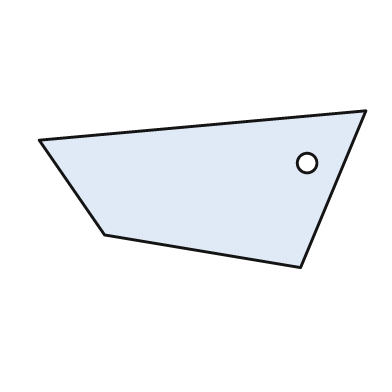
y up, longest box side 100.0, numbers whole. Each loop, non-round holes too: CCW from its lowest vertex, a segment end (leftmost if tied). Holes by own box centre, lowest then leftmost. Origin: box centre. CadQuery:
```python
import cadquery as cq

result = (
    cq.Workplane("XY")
    .moveTo(30.0, -24.0)
    .lineTo(50.0, 24.0)
    .lineTo(-50.0, 15.0)
    .lineTo(-30.0, -14.0)
    .close()
    .moveTo(32.0, 8.0)
    .circle(3.0)
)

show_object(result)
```